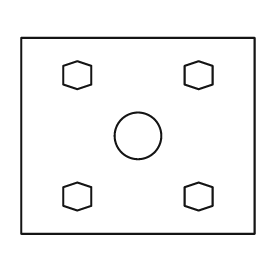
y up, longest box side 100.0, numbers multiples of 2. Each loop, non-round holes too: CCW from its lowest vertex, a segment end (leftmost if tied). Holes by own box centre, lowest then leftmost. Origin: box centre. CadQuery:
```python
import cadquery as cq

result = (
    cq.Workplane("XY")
    .moveTo(-50.0, -42.0)
    .lineTo(50.0, -42.0)
    .lineTo(50.0, 42.0)
    .lineTo(-50.0, 42.0)
    .close()
    .moveTo(-26.0, -32.0)
    .lineTo(-20.0, -30.0)
    .lineTo(-20.0, -22.0)
    .lineTo(-26.0, -20.0)
    .lineTo(-32.0, -22.0)
    .lineTo(-32.0, -30.0)
    .close()
    .moveTo(26.0, -32.0)
    .lineTo(32.0, -30.0)
    .lineTo(32.0, -22.0)
    .lineTo(26.0, -20.0)
    .lineTo(20.0, -22.0)
    .lineTo(20.0, -30.0)
    .close()
    .moveTo(0.0, 0.0)
    .circle(10.0)
    .moveTo(-26.0, 20.0)
    .lineTo(-20.0, 22.0)
    .lineTo(-20.0, 30.0)
    .lineTo(-26.0, 32.0)
    .lineTo(-32.0, 30.0)
    .lineTo(-32.0, 22.0)
    .close()
    .moveTo(26.0, 20.0)
    .lineTo(32.0, 22.0)
    .lineTo(32.0, 30.0)
    .lineTo(26.0, 32.0)
    .lineTo(20.0, 30.0)
    .lineTo(20.0, 22.0)
    .close()
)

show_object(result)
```